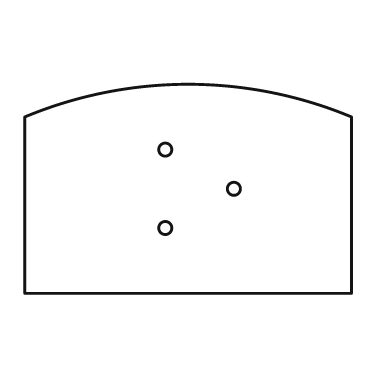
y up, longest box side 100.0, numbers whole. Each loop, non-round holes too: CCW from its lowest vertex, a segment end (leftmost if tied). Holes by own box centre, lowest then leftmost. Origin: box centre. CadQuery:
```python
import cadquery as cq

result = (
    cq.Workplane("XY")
    .moveTo(-50.0, -32.0)
    .lineTo(50.0, -32.0)
    .lineTo(50.0, 22.0)
    .threePointArc((0.0, 32.0), (-50.0, 22.0))
    .close()
    .moveTo(-7.0, -12.0)
    .circle(2.0)
    .moveTo(14.0, 0.0)
    .circle(2.0)
    .moveTo(-7.0, 12.0)
    .circle(2.0)
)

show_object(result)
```